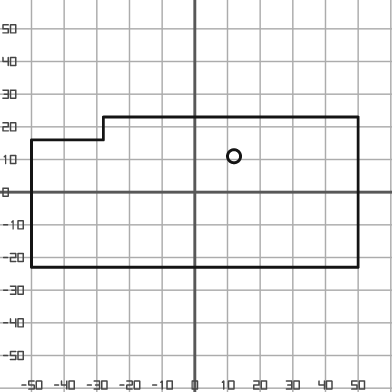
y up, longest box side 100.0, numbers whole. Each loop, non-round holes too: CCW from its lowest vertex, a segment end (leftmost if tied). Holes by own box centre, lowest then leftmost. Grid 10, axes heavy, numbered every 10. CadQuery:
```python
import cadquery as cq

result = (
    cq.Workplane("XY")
    .moveTo(-50.0, -23.0)
    .lineTo(50.0, -23.0)
    .lineTo(50.0, 23.0)
    .lineTo(-28.0, 23.0)
    .lineTo(-28.0, 16.0)
    .lineTo(-50.0, 16.0)
    .close()
    .moveTo(12.0, 11.0)
    .circle(2.0)
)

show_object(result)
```